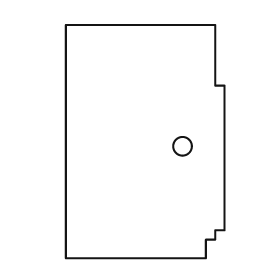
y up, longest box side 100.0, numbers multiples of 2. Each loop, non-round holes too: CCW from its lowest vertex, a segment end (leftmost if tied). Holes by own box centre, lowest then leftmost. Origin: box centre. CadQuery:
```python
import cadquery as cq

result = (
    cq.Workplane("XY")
    .moveTo(-34.0, -50.0)
    .lineTo(26.0, -50.0)
    .lineTo(26.0, -42.0)
    .lineTo(30.0, -42.0)
    .lineTo(30.0, -38.0)
    .lineTo(34.0, -38.0)
    .lineTo(34.0, 24.0)
    .lineTo(30.0, 24.0)
    .lineTo(30.0, 50.0)
    .lineTo(-34.0, 50.0)
    .close()
    .moveTo(16.0, -2.0)
    .circle(4.0)
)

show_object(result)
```